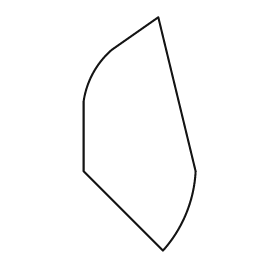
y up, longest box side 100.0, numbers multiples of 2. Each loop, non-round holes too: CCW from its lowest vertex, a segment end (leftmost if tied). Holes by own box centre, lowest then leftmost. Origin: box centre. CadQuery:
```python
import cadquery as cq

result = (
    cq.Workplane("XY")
    .moveTo(10.0, -50.0)
    .threePointArc((20.0, -34.0), (24.0, -16.0))
    .lineTo(8.0, 50.0)
    .lineTo(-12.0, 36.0)
    .threePointArc((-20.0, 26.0), (-24.0, 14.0))
    .lineTo(-24.0, -16.0)
    .close()
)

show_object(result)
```